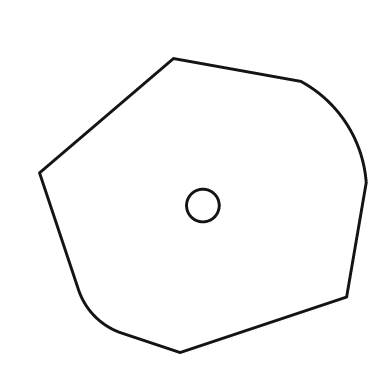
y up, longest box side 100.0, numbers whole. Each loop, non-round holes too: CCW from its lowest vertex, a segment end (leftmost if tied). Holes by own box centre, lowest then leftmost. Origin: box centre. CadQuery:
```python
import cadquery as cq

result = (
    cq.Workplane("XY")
    .moveTo(-7.0, -45.0)
    .lineTo(44.0, -28.0)
    .lineTo(50.0, 7.0)
    .threePointArc((44.0, 25.0), (30.0, 38.0))
    .lineTo(-9.0, 45.0)
    .lineTo(-50.0, 10.0)
    .lineTo(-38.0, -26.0)
    .threePointArc((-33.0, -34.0), (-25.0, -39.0))
    .close()
    .moveTo(0.0, 0.0)
    .circle(5.0)
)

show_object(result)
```